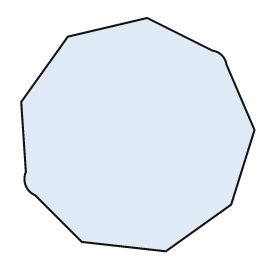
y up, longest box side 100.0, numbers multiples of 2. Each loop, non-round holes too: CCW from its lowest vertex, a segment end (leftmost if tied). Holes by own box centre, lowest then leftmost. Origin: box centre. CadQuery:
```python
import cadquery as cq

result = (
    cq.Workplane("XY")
    .moveTo(12.0, -50.0)
    .lineTo(40.0, -30.0)
    .lineTo(50.0, 2.0)
    .lineTo(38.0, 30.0)
    .threePointArc((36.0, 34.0), (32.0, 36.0))
    .lineTo(4.0, 50.0)
    .lineTo(-30.0, 42.0)
    .lineTo(-50.0, 14.0)
    .lineTo(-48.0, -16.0)
    .threePointArc((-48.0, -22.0), (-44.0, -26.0))
    .lineTo(-24.0, -46.0)
    .close()
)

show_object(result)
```